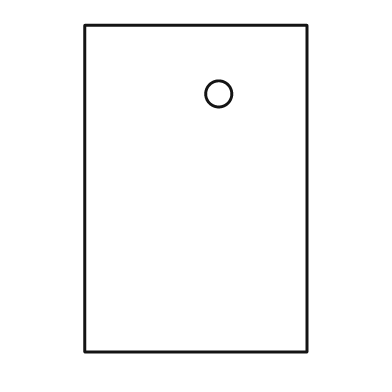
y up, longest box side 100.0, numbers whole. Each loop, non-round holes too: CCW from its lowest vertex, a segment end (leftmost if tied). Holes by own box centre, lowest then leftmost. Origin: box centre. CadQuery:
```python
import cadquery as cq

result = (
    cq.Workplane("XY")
    .moveTo(-34.0, -50.0)
    .lineTo(34.0, -50.0)
    .lineTo(34.0, 50.0)
    .lineTo(-34.0, 50.0)
    .close()
    .moveTo(7.0, 29.0)
    .circle(4.0)
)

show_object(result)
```